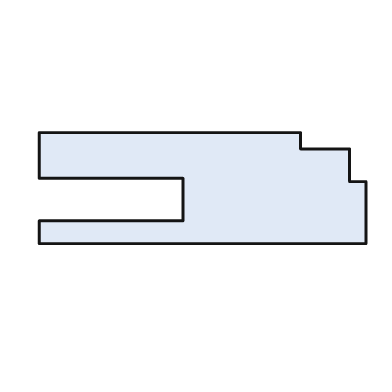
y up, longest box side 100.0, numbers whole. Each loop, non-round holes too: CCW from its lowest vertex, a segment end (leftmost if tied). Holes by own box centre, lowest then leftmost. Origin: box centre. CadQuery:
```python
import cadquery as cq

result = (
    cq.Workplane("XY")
    .moveTo(-50.0, -17.0)
    .lineTo(50.0, -17.0)
    .lineTo(50.0, 2.0)
    .lineTo(45.0, 2.0)
    .lineTo(45.0, 12.0)
    .lineTo(30.0, 12.0)
    .lineTo(30.0, 17.0)
    .lineTo(-50.0, 17.0)
    .lineTo(-50.0, 3.0)
    .lineTo(-6.0, 3.0)
    .lineTo(-6.0, -10.0)
    .lineTo(-50.0, -10.0)
    .close()
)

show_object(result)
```